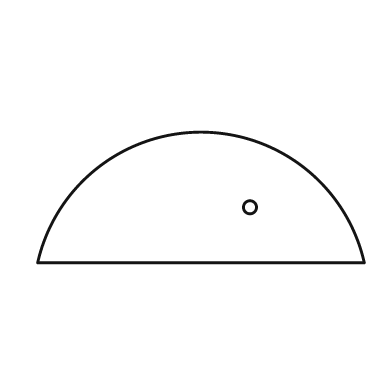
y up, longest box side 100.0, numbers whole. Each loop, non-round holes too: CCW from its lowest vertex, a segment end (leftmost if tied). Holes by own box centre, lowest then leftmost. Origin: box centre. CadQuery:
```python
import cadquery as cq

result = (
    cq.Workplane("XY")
    .moveTo(-50.0, -20.0)
    .lineTo(50.0, -20.0)
    .threePointArc((0.0, 20.0), (-50.0, -20.0))
    .close()
    .moveTo(15.0, -3.0)
    .circle(2.0)
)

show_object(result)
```